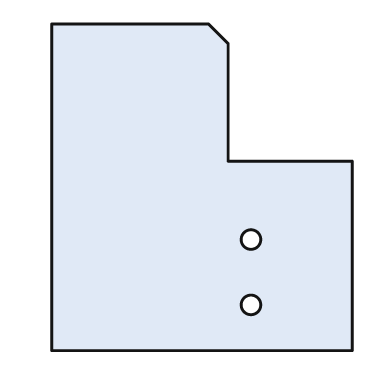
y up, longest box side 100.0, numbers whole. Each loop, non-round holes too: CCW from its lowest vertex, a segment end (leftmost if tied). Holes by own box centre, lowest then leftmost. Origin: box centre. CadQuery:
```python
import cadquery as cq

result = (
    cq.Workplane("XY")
    .moveTo(-46.0, -50.0)
    .lineTo(46.0, -50.0)
    .lineTo(46.0, 8.0)
    .lineTo(8.0, 8.0)
    .lineTo(8.0, 44.0)
    .lineTo(2.0, 50.0)
    .lineTo(-46.0, 50.0)
    .close()
    .moveTo(15.0, -36.0)
    .circle(3.0)
    .moveTo(15.0, -16.0)
    .circle(3.0)
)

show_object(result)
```